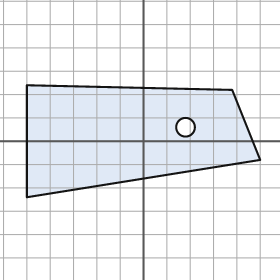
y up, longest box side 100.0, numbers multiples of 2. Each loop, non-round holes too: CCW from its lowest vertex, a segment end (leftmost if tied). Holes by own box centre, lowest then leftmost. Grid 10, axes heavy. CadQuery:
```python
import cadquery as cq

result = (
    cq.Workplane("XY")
    .moveTo(-50.0, -24.0)
    .lineTo(50.0, -8.0)
    .lineTo(38.0, 22.0)
    .lineTo(-50.0, 24.0)
    .close()
    .moveTo(18.0, 6.0)
    .circle(4.0)
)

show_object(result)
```